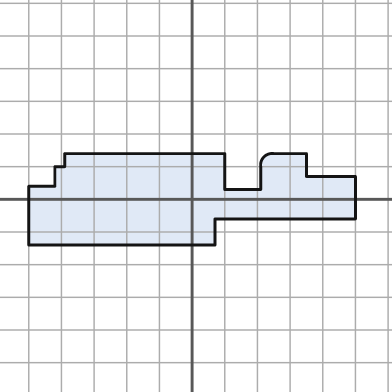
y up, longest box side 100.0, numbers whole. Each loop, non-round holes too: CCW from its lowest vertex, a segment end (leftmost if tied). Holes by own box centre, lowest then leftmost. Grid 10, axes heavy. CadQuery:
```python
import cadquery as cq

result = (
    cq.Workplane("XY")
    .moveTo(-50.0, -14.0)
    .lineTo(7.0, -14.0)
    .lineTo(7.0, -6.0)
    .lineTo(50.0, -6.0)
    .lineTo(50.0, 7.0)
    .lineTo(35.0, 7.0)
    .lineTo(35.0, 14.0)
    .lineTo(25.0, 14.0)
    .threePointArc((22.0, 13.0), (21.0, 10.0))
    .lineTo(21.0, 3.0)
    .lineTo(10.0, 3.0)
    .lineTo(10.0, 14.0)
    .lineTo(-39.0, 14.0)
    .lineTo(-39.0, 10.0)
    .lineTo(-42.0, 10.0)
    .lineTo(-42.0, 4.0)
    .lineTo(-50.0, 4.0)
    .close()
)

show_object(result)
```